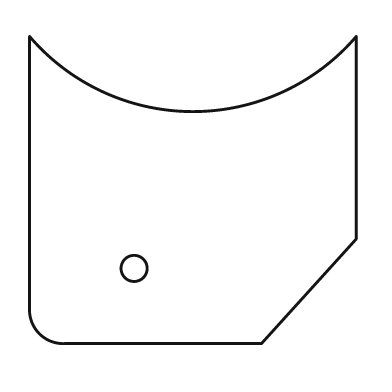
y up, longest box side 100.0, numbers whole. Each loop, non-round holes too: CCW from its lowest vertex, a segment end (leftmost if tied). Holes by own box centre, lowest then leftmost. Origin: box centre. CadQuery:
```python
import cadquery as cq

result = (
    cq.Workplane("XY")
    .moveTo(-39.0, -47.0)
    .lineTo(21.0, -47.0)
    .lineTo(50.0, -15.0)
    .lineTo(50.0, 47.0)
    .threePointArc((0.0, 24.0), (-50.0, 47.0))
    .lineTo(-50.0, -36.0)
    .threePointArc((-47.0, -44.0), (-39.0, -47.0))
    .close()
    .moveTo(-18.0, -24.0)
    .circle(4.0)
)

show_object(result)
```